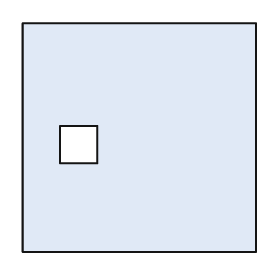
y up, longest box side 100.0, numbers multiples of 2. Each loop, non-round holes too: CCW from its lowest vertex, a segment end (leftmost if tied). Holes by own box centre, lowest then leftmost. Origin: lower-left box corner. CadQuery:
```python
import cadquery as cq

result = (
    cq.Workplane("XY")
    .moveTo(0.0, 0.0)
    .lineTo(100.0, 0.0)
    .lineTo(100.0, 98.0)
    .lineTo(0.0, 98.0)
    .close()
    .moveTo(16.0, 38.0)
    .lineTo(32.0, 38.0)
    .lineTo(32.0, 54.0)
    .lineTo(16.0, 54.0)
    .close()
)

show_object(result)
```